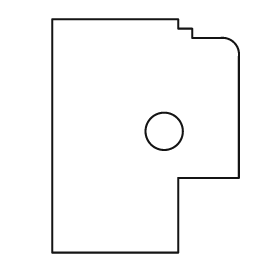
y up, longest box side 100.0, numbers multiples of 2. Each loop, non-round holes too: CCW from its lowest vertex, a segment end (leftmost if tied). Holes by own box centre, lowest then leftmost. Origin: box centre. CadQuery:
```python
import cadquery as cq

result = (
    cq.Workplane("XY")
    .moveTo(-40.0, -50.0)
    .lineTo(14.0, -50.0)
    .lineTo(14.0, -18.0)
    .lineTo(40.0, -18.0)
    .lineTo(40.0, 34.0)
    .threePointArc((38.0, 40.0), (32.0, 42.0))
    .lineTo(20.0, 42.0)
    .lineTo(20.0, 46.0)
    .lineTo(14.0, 46.0)
    .lineTo(14.0, 50.0)
    .lineTo(-40.0, 50.0)
    .close()
    .moveTo(8.0, 2.0)
    .circle(8.0)
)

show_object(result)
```